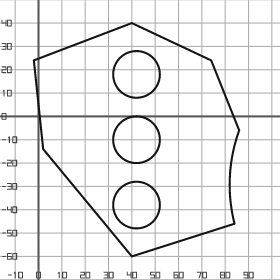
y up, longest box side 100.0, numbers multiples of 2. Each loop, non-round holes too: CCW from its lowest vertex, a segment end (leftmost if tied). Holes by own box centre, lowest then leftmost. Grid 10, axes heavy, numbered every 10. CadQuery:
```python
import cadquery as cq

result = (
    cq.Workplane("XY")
    .moveTo(40.0, -60.0)
    .lineTo(84.0, -46.0)
    .threePointArc((82.0, -26.0), (86.0, -6.0))
    .lineTo(74.0, 24.0)
    .lineTo(40.0, 40.0)
    .lineTo(-2.0, 24.0)
    .lineTo(2.0, -14.0)
    .close()
    .moveTo(42.0, -38.0)
    .circle(10.0)
    .moveTo(42.0, -10.0)
    .circle(10.0)
    .moveTo(42.0, 18.0)
    .circle(10.0)
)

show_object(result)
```